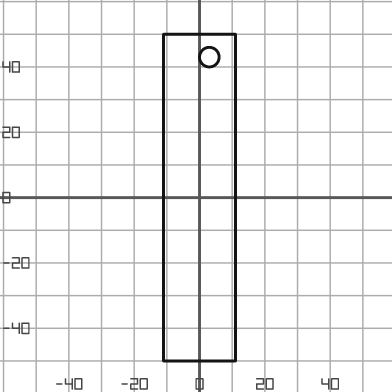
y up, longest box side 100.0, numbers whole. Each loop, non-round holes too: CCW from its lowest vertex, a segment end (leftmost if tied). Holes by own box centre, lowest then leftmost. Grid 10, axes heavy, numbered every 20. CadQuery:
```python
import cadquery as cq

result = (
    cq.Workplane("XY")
    .moveTo(-11.0, -50.0)
    .lineTo(11.0, -50.0)
    .lineTo(11.0, 50.0)
    .lineTo(-11.0, 50.0)
    .close()
    .moveTo(3.0, 43.0)
    .circle(3.0)
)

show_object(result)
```